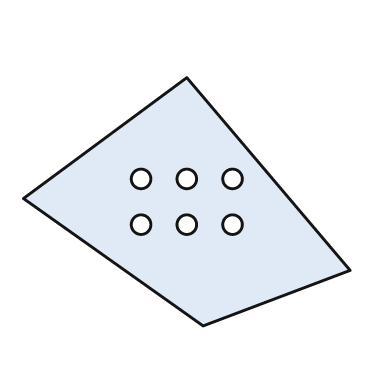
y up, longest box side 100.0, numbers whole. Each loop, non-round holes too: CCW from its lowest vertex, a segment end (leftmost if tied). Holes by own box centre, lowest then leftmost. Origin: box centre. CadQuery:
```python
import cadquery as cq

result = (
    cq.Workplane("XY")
    .moveTo(5.0, -38.0)
    .lineTo(50.0, -21.0)
    .lineTo(0.0, 38.0)
    .lineTo(-50.0, 1.0)
    .close()
    .moveTo(-14.0, -7.0)
    .circle(3.0)
    .moveTo(0.0, -7.0)
    .circle(3.0)
    .moveTo(14.0, -7.0)
    .circle(3.0)
    .moveTo(-14.0, 7.0)
    .circle(3.0)
    .moveTo(0.0, 7.0)
    .circle(3.0)
    .moveTo(14.0, 7.0)
    .circle(3.0)
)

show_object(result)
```